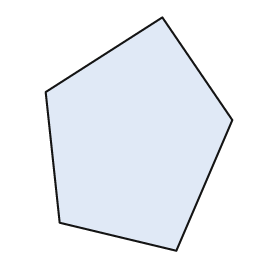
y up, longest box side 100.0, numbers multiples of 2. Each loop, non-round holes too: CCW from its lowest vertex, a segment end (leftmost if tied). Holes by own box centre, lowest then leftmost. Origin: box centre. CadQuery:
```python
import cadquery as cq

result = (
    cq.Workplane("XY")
    .moveTo(16.0, -50.0)
    .lineTo(40.0, 6.0)
    .lineTo(10.0, 50.0)
    .lineTo(-40.0, 18.0)
    .lineTo(-34.0, -38.0)
    .close()
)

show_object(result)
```